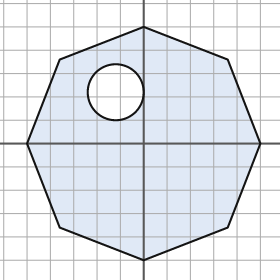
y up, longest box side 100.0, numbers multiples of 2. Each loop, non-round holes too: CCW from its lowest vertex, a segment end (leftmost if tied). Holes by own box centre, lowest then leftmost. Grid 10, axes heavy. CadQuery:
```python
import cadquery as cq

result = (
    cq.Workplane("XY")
    .moveTo(0.0, -50.0)
    .lineTo(36.0, -36.0)
    .lineTo(50.0, 0.0)
    .lineTo(36.0, 36.0)
    .lineTo(0.0, 50.0)
    .lineTo(-36.0, 36.0)
    .lineTo(-50.0, 0.0)
    .lineTo(-36.0, -36.0)
    .close()
    .moveTo(-12.0, 22.0)
    .circle(12.0)
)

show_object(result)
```